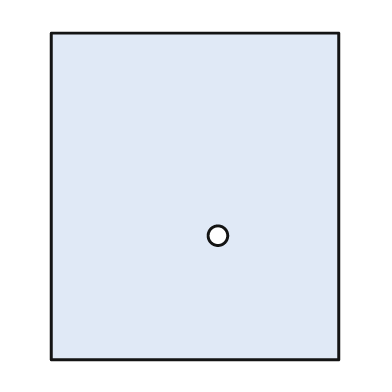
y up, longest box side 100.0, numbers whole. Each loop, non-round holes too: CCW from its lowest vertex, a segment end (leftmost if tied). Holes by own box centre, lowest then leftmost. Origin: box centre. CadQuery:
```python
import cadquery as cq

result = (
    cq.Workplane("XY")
    .moveTo(-44.0, -50.0)
    .lineTo(44.0, -50.0)
    .lineTo(44.0, 50.0)
    .lineTo(-44.0, 50.0)
    .close()
    .moveTo(7.0, -12.0)
    .circle(3.0)
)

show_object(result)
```